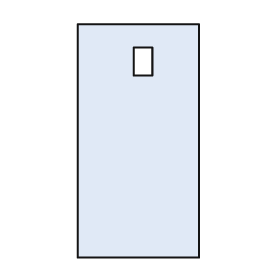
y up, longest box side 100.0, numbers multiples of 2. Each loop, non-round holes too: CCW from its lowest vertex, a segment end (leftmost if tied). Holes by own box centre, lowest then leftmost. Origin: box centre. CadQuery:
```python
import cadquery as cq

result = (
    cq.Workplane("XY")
    .moveTo(-26.0, -50.0)
    .lineTo(26.0, -50.0)
    .lineTo(26.0, 50.0)
    .lineTo(-26.0, 50.0)
    .close()
    .moveTo(-2.0, 28.0)
    .lineTo(6.0, 28.0)
    .lineTo(6.0, 40.0)
    .lineTo(-2.0, 40.0)
    .close()
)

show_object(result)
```